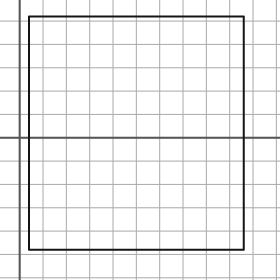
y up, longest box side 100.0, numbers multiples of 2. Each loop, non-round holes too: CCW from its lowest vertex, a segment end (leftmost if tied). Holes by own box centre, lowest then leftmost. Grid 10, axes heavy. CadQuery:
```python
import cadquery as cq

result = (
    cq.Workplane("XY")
    .moveTo(4.0, -48.0)
    .lineTo(96.0, -48.0)
    .lineTo(96.0, 52.0)
    .lineTo(4.0, 52.0)
    .close()
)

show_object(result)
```